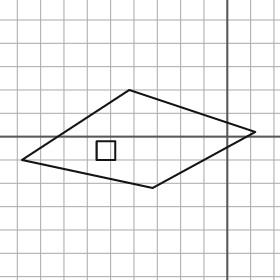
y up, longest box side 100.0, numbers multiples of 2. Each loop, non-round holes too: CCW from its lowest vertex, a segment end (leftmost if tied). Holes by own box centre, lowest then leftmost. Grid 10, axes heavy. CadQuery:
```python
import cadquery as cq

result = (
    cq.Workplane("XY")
    .moveTo(-32.0, -22.0)
    .lineTo(12.0, 2.0)
    .lineTo(-42.0, 20.0)
    .lineTo(-88.0, -10.0)
    .close()
    .moveTo(-56.0, -10.0)
    .lineTo(-48.0, -10.0)
    .lineTo(-48.0, -2.0)
    .lineTo(-56.0, -2.0)
    .close()
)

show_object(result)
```